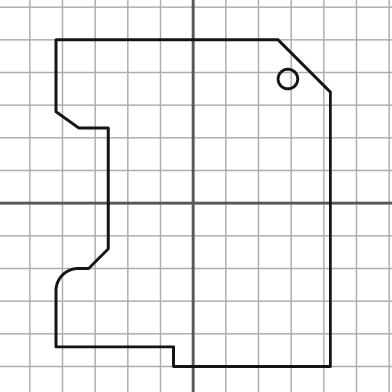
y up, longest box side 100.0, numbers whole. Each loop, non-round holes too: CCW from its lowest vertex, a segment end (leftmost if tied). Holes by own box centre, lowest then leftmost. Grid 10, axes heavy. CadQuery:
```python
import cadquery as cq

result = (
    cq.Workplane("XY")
    .moveTo(-6.0, -50.0)
    .lineTo(42.0, -50.0)
    .lineTo(42.0, 34.0)
    .lineTo(26.0, 50.0)
    .lineTo(-42.0, 50.0)
    .lineTo(-42.0, 28.0)
    .lineTo(-35.0, 23.0)
    .lineTo(-26.0, 23.0)
    .lineTo(-26.0, -14.0)
    .lineTo(-32.0, -20.0)
    .lineTo(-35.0, -20.0)
    .threePointArc((-40.0, -22.0), (-42.0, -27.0))
    .lineTo(-42.0, -44.0)
    .lineTo(-6.0, -44.0)
    .close()
    .moveTo(29.0, 38.0)
    .circle(3.0)
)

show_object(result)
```